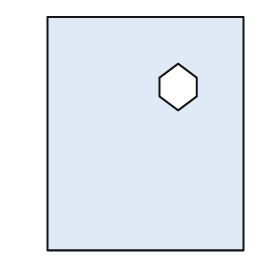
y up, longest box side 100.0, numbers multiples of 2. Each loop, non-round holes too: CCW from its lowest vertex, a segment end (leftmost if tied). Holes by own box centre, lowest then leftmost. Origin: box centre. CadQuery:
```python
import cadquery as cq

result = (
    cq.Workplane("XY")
    .moveTo(-42.0, -50.0)
    .lineTo(42.0, -50.0)
    .lineTo(42.0, 50.0)
    .lineTo(-42.0, 50.0)
    .close()
    .moveTo(14.0, 10.0)
    .lineTo(22.0, 16.0)
    .lineTo(22.0, 24.0)
    .lineTo(14.0, 30.0)
    .lineTo(6.0, 24.0)
    .lineTo(6.0, 16.0)
    .close()
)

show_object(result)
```